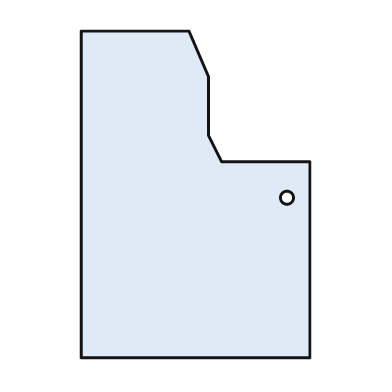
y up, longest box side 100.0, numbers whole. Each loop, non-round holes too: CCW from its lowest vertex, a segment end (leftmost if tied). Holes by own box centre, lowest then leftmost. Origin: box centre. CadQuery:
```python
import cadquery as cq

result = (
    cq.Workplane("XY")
    .moveTo(-35.0, -50.0)
    .lineTo(35.0, -50.0)
    .lineTo(35.0, 10.0)
    .lineTo(8.0, 10.0)
    .lineTo(4.0, 18.0)
    .lineTo(4.0, 36.0)
    .lineTo(-2.0, 50.0)
    .lineTo(-35.0, 50.0)
    .close()
    .moveTo(28.0, -1.0)
    .circle(2.0)
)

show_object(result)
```